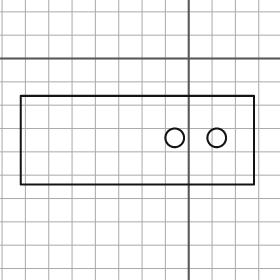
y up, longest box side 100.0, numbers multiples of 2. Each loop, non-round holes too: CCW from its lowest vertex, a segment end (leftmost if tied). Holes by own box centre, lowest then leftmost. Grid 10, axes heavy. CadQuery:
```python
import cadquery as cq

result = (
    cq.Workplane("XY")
    .moveTo(-72.0, -54.0)
    .lineTo(28.0, -54.0)
    .lineTo(28.0, -16.0)
    .lineTo(-72.0, -16.0)
    .close()
    .moveTo(-6.0, -34.0)
    .circle(4.0)
    .moveTo(12.0, -34.0)
    .circle(4.0)
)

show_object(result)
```